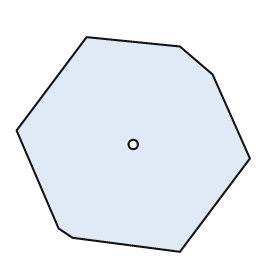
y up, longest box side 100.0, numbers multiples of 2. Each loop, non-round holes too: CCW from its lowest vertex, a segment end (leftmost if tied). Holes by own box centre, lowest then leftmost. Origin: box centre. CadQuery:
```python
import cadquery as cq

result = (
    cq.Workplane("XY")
    .moveTo(20.0, -46.0)
    .lineTo(50.0, -6.0)
    .lineTo(34.0, 30.0)
    .lineTo(20.0, 42.0)
    .lineTo(-20.0, 46.0)
    .lineTo(-50.0, 6.0)
    .lineTo(-32.0, -36.0)
    .lineTo(-26.0, -40.0)
    .close()
    .moveTo(0.0, 0.0)
    .circle(2.0)
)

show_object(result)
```